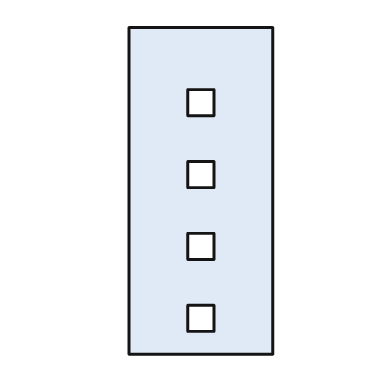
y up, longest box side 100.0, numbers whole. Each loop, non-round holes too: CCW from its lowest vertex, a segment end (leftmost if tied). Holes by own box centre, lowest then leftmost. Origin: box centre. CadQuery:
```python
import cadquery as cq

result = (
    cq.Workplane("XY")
    .moveTo(-22.0, -50.0)
    .lineTo(22.0, -50.0)
    .lineTo(22.0, 50.0)
    .lineTo(-22.0, 50.0)
    .close()
    .moveTo(-4.0, -43.0)
    .lineTo(4.0, -43.0)
    .lineTo(4.0, -35.0)
    .lineTo(-4.0, -35.0)
    .close()
    .moveTo(-4.0, -21.0)
    .lineTo(4.0, -21.0)
    .lineTo(4.0, -13.0)
    .lineTo(-4.0, -13.0)
    .close()
    .moveTo(-4.0, 1.0)
    .lineTo(4.0, 1.0)
    .lineTo(4.0, 9.0)
    .lineTo(-4.0, 9.0)
    .close()
    .moveTo(-4.0, 23.0)
    .lineTo(4.0, 23.0)
    .lineTo(4.0, 31.0)
    .lineTo(-4.0, 31.0)
    .close()
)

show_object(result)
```